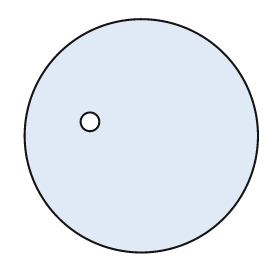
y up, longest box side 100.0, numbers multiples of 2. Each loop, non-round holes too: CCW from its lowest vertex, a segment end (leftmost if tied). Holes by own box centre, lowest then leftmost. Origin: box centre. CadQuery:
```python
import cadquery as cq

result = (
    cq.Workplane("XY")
    .moveTo(0.0, 0.0)
    .circle(50.0)
    .moveTo(-22.0, 6.0)
    .circle(4.0)
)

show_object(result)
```